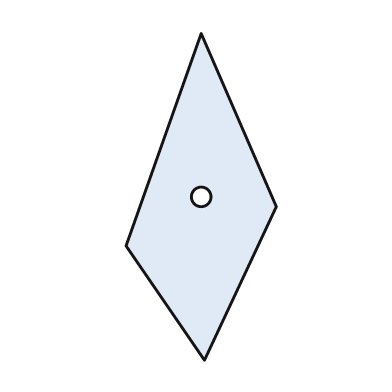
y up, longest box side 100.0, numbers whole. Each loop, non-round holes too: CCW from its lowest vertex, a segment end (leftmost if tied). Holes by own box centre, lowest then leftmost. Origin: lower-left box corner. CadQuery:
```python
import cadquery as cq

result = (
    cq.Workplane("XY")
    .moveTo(24.0, 0.0)
    .lineTo(46.0, 47.0)
    .lineTo(23.0, 100.0)
    .lineTo(0.0, 35.0)
    .close()
    .moveTo(23.0, 50.0)
    .circle(3.0)
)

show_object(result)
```